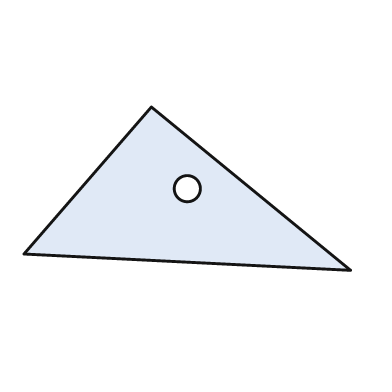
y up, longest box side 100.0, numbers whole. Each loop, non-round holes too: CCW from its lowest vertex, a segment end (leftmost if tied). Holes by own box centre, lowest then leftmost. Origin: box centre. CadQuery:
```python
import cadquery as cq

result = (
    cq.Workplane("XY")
    .moveTo(50.0, -25.0)
    .lineTo(-11.0, 25.0)
    .lineTo(-50.0, -20.0)
    .close()
    .moveTo(0.0, 0.0)
    .circle(4.0)
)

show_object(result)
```